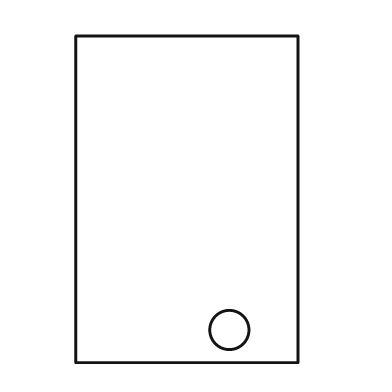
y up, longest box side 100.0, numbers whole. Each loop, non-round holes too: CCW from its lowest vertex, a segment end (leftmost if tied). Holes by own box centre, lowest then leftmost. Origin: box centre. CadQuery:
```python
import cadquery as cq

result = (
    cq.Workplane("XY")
    .moveTo(-34.0, -50.0)
    .lineTo(34.0, -50.0)
    .lineTo(34.0, 50.0)
    .lineTo(-34.0, 50.0)
    .close()
    .moveTo(13.0, -40.0)
    .circle(6.0)
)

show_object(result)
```